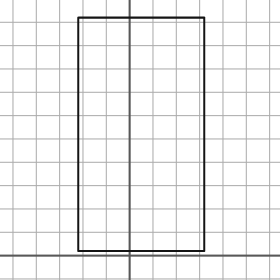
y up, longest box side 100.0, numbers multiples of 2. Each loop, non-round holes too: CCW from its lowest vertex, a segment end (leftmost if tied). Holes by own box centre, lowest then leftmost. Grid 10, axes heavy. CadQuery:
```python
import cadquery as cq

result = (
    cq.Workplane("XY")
    .moveTo(-22.0, 2.0)
    .lineTo(32.0, 2.0)
    .lineTo(32.0, 102.0)
    .lineTo(-22.0, 102.0)
    .close()
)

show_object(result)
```